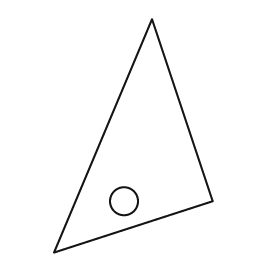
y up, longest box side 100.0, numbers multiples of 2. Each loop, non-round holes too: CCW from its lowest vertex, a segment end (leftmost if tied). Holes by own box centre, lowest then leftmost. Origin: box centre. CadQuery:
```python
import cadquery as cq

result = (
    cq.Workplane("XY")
    .moveTo(-34.0, -50.0)
    .lineTo(34.0, -28.0)
    .lineTo(8.0, 50.0)
    .close()
    .moveTo(-4.0, -28.0)
    .circle(6.0)
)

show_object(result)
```